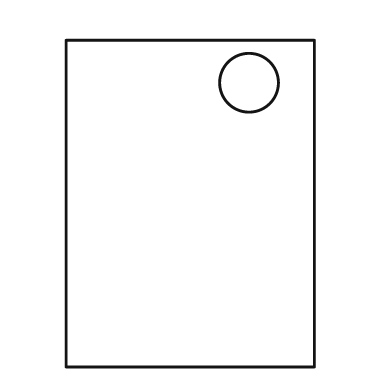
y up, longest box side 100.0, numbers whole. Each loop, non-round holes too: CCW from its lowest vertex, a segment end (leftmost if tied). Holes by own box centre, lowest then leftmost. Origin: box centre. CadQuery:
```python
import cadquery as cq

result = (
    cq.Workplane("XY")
    .moveTo(-38.0, -50.0)
    .lineTo(38.0, -50.0)
    .lineTo(38.0, 50.0)
    .lineTo(-38.0, 50.0)
    .close()
    .moveTo(18.0, 37.0)
    .circle(9.0)
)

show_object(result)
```